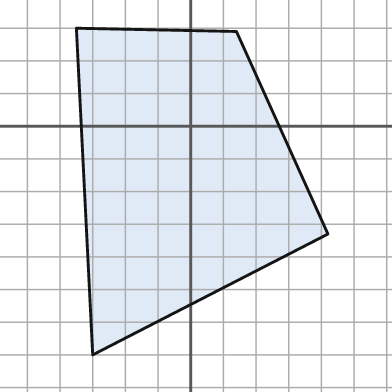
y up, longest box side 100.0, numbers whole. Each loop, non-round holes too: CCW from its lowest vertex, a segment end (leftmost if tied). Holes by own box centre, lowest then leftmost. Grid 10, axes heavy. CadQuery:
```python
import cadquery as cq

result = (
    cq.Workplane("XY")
    .moveTo(-30.0, -70.0)
    .lineTo(42.0, -33.0)
    .lineTo(14.0, 29.0)
    .lineTo(-35.0, 30.0)
    .close()
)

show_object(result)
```